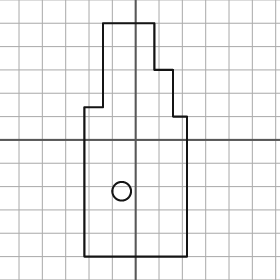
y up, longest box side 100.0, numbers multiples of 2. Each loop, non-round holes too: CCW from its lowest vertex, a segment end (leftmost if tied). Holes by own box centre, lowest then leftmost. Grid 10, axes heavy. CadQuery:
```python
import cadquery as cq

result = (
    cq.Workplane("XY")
    .moveTo(-22.0, -50.0)
    .lineTo(22.0, -50.0)
    .lineTo(22.0, 10.0)
    .lineTo(16.0, 10.0)
    .lineTo(16.0, 30.0)
    .lineTo(8.0, 30.0)
    .lineTo(8.0, 50.0)
    .lineTo(-14.0, 50.0)
    .lineTo(-14.0, 14.0)
    .lineTo(-22.0, 14.0)
    .close()
    .moveTo(-6.0, -22.0)
    .circle(4.0)
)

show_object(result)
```